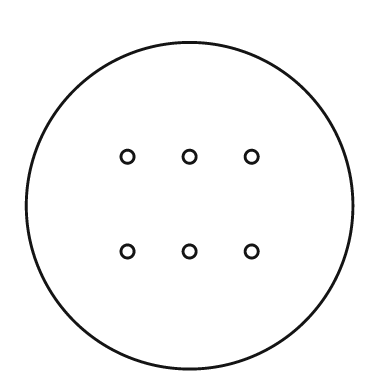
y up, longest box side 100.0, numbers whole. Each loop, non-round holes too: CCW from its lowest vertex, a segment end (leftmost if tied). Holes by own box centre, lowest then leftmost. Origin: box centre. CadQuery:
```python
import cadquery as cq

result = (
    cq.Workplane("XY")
    .moveTo(0.0, 0.0)
    .circle(50.0)
    .moveTo(-19.0, -14.0)
    .circle(2.0)
    .moveTo(0.0, -14.0)
    .circle(2.0)
    .moveTo(19.0, -14.0)
    .circle(2.0)
    .moveTo(-19.0, 15.0)
    .circle(2.0)
    .moveTo(0.0, 15.0)
    .circle(2.0)
    .moveTo(19.0, 15.0)
    .circle(2.0)
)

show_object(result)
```